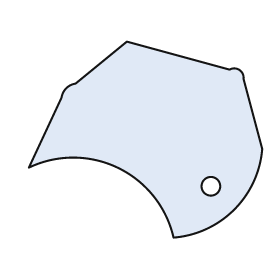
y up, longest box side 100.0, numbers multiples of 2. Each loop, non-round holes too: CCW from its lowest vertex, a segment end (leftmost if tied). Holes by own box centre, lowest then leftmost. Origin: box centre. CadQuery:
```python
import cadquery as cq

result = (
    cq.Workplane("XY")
    .moveTo(12.0, -42.0)
    .threePointArc((38.0, -30.0), (50.0, -4.0))
    .lineTo(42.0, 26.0)
    .threePointArc((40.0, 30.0), (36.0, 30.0))
    .lineTo(-8.0, 42.0)
    .lineTo(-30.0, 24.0)
    .threePointArc((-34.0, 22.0), (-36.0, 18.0))
    .lineTo(-50.0, -12.0)
    .threePointArc((-12.0, -12.0), (12.0, -42.0))
    .close()
    .moveTo(28.0, -20.0)
    .circle(4.0)
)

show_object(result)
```